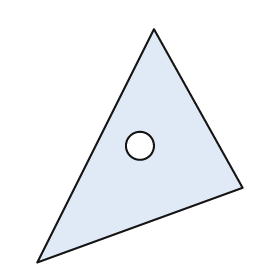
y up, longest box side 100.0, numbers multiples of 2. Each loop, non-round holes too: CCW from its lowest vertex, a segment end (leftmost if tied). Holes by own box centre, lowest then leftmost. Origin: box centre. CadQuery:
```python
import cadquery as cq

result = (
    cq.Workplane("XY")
    .moveTo(-44.0, -50.0)
    .lineTo(44.0, -18.0)
    .lineTo(6.0, 50.0)
    .close()
    .moveTo(0.0, 0.0)
    .circle(6.0)
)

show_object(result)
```